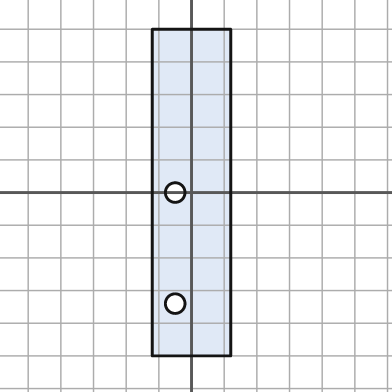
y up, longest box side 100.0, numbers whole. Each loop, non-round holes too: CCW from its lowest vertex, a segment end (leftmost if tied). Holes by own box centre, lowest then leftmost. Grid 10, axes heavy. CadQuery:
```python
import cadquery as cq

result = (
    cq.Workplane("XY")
    .moveTo(-12.0, -50.0)
    .lineTo(12.0, -50.0)
    .lineTo(12.0, 50.0)
    .lineTo(-12.0, 50.0)
    .close()
    .moveTo(-5.0, -34.0)
    .circle(3.0)
    .moveTo(-5.0, 0.0)
    .circle(3.0)
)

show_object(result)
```